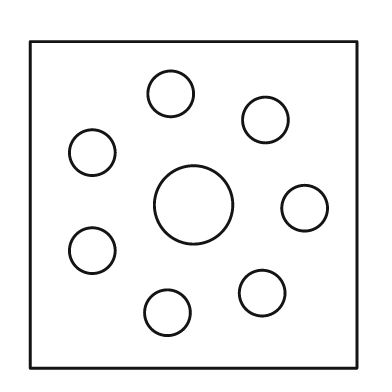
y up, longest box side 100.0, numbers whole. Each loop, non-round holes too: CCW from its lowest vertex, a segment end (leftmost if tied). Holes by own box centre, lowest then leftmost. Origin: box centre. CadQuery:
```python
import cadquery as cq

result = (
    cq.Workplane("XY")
    .moveTo(-50.0, -50.0)
    .lineTo(50.0, -50.0)
    .lineTo(50.0, 50.0)
    .lineTo(-50.0, 50.0)
    .close()
    .moveTo(-8.0, -33.0)
    .circle(7.0)
    .moveTo(21.0, -27.0)
    .circle(7.0)
    .moveTo(-31.0, -14.0)
    .circle(7.0)
    .moveTo(34.0, -1.0)
    .circle(7.0)
    .moveTo(0.0, 0.0)
    .circle(12.0)
    .moveTo(-31.0, 16.0)
    .circle(7.0)
    .moveTo(22.0, 26.0)
    .circle(7.0)
    .moveTo(-7.0, 34.0)
    .circle(7.0)
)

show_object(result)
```